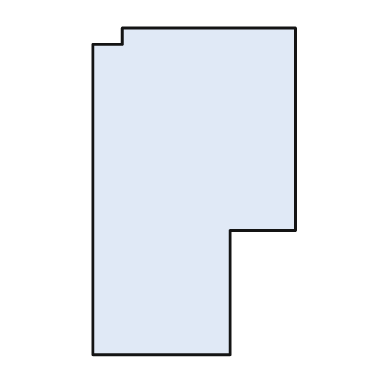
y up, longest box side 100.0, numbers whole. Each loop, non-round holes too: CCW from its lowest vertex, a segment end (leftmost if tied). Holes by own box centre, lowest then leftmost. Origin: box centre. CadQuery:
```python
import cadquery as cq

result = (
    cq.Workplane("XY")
    .moveTo(-31.0, -50.0)
    .lineTo(11.0, -50.0)
    .lineTo(11.0, -12.0)
    .lineTo(31.0, -12.0)
    .lineTo(31.0, 50.0)
    .lineTo(-22.0, 50.0)
    .lineTo(-22.0, 45.0)
    .lineTo(-31.0, 45.0)
    .close()
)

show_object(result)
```